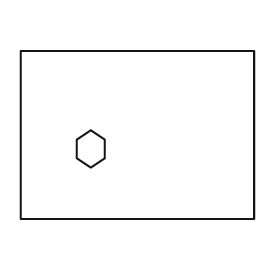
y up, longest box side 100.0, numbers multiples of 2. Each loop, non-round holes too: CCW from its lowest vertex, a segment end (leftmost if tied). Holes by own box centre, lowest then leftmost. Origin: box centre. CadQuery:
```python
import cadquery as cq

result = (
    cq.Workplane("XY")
    .moveTo(-50.0, -36.0)
    .lineTo(50.0, -36.0)
    .lineTo(50.0, 36.0)
    .lineTo(-50.0, 36.0)
    .close()
    .moveTo(-20.0, -14.0)
    .lineTo(-14.0, -10.0)
    .lineTo(-14.0, -2.0)
    .lineTo(-20.0, 2.0)
    .lineTo(-26.0, -2.0)
    .lineTo(-26.0, -10.0)
    .close()
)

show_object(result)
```